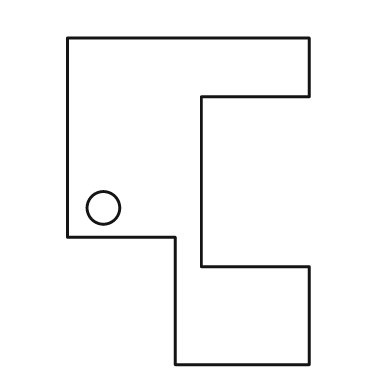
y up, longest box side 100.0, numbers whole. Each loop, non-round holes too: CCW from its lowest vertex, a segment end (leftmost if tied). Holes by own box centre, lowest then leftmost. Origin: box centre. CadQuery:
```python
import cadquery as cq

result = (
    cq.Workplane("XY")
    .moveTo(-4.0, -50.0)
    .lineTo(37.0, -50.0)
    .lineTo(37.0, -20.0)
    .lineTo(4.0, -20.0)
    .lineTo(4.0, 32.0)
    .lineTo(37.0, 32.0)
    .lineTo(37.0, 50.0)
    .lineTo(-37.0, 50.0)
    .lineTo(-37.0, -11.0)
    .lineTo(-4.0, -11.0)
    .close()
    .moveTo(-26.0, -2.0)
    .circle(5.0)
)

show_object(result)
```